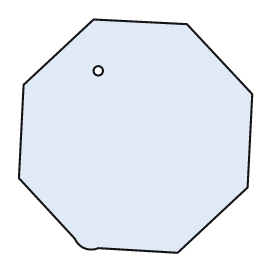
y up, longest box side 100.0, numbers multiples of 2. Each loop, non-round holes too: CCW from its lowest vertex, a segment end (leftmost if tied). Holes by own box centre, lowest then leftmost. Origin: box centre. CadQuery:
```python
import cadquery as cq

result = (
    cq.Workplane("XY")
    .moveTo(18.0, -50.0)
    .lineTo(48.0, -22.0)
    .lineTo(50.0, 18.0)
    .lineTo(22.0, 48.0)
    .lineTo(-18.0, 50.0)
    .lineTo(-48.0, 22.0)
    .lineTo(-50.0, -18.0)
    .lineTo(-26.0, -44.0)
    .threePointArc((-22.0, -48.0), (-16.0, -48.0))
    .close()
    .moveTo(-16.0, 28.0)
    .circle(2.0)
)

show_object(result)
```